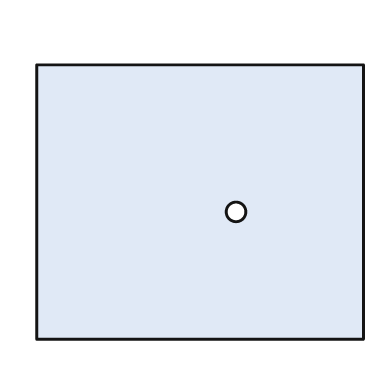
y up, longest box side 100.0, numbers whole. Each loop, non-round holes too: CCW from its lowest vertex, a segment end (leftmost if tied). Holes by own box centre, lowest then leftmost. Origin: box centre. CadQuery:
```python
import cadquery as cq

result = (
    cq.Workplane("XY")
    .moveTo(-50.0, -42.0)
    .lineTo(50.0, -42.0)
    .lineTo(50.0, 42.0)
    .lineTo(-50.0, 42.0)
    .close()
    .moveTo(11.0, -3.0)
    .circle(3.0)
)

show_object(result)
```